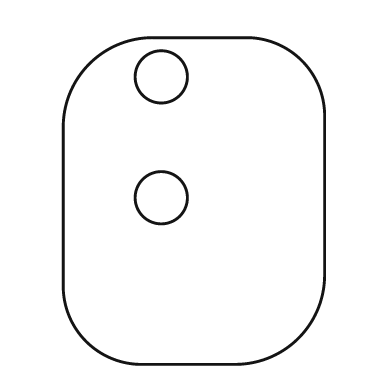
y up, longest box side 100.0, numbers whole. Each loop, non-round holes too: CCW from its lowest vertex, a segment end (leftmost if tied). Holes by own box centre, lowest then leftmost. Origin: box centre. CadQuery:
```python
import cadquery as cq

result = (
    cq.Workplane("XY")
    .moveTo(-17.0, -50.0)
    .lineTo(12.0, -50.0)
    .threePointArc((32.0, -42.0), (40.0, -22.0))
    .lineTo(40.0, 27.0)
    .threePointArc((33.0, 43.0), (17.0, 50.0))
    .lineTo(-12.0, 50.0)
    .threePointArc((-32.0, 42.0), (-40.0, 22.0))
    .lineTo(-40.0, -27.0)
    .threePointArc((-33.0, -43.0), (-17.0, -50.0))
    .close()
    .moveTo(-10.0, 1.0)
    .circle(8.0)
    .moveTo(-10.0, 38.0)
    .circle(8.0)
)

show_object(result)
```